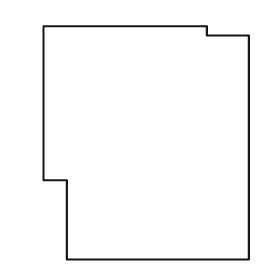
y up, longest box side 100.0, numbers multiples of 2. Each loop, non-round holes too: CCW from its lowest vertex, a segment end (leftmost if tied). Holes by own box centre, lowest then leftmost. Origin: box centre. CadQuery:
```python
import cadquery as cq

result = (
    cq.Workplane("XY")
    .moveTo(-34.0, -50.0)
    .lineTo(44.0, -50.0)
    .lineTo(44.0, 46.0)
    .lineTo(26.0, 46.0)
    .lineTo(26.0, 50.0)
    .lineTo(-44.0, 50.0)
    .lineTo(-44.0, -16.0)
    .lineTo(-34.0, -16.0)
    .close()
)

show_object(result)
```